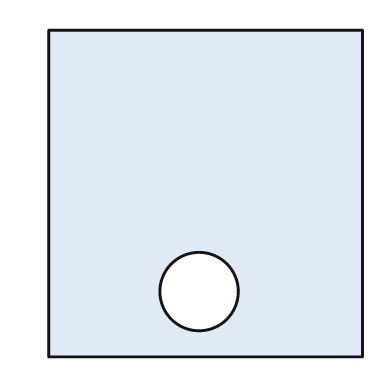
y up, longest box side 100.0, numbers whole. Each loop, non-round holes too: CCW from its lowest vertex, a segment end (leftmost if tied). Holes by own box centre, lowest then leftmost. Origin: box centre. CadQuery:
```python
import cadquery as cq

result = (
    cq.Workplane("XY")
    .moveTo(-48.0, -50.0)
    .lineTo(48.0, -50.0)
    .lineTo(48.0, 50.0)
    .lineTo(-48.0, 50.0)
    .close()
    .moveTo(-2.0, -30.0)
    .circle(12.0)
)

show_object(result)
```